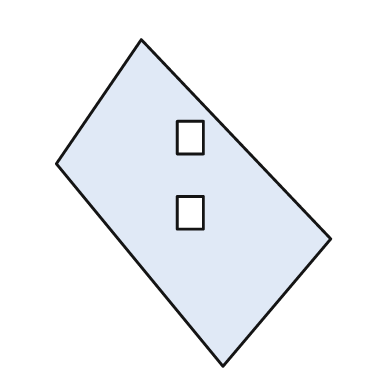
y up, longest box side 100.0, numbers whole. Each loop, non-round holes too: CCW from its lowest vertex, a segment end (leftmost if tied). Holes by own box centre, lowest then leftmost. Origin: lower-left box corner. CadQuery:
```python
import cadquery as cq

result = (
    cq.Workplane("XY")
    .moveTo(51.0, 0.0)
    .lineTo(84.0, 39.0)
    .lineTo(26.0, 100.0)
    .lineTo(0.0, 62.0)
    .close()
    .moveTo(37.0, 42.0)
    .lineTo(45.0, 42.0)
    .lineTo(45.0, 52.0)
    .lineTo(37.0, 52.0)
    .close()
    .moveTo(37.0, 65.0)
    .lineTo(45.0, 65.0)
    .lineTo(45.0, 75.0)
    .lineTo(37.0, 75.0)
    .close()
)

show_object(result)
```